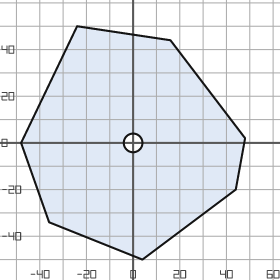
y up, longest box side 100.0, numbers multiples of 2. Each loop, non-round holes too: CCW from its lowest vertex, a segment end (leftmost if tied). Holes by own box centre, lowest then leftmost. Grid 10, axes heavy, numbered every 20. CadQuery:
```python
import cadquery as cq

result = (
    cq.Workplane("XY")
    .moveTo(4.0, -50.0)
    .lineTo(44.0, -20.0)
    .lineTo(48.0, 2.0)
    .lineTo(16.0, 44.0)
    .lineTo(-24.0, 50.0)
    .lineTo(-48.0, 0.0)
    .lineTo(-36.0, -34.0)
    .close()
    .moveTo(0.0, 0.0)
    .circle(4.0)
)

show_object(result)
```